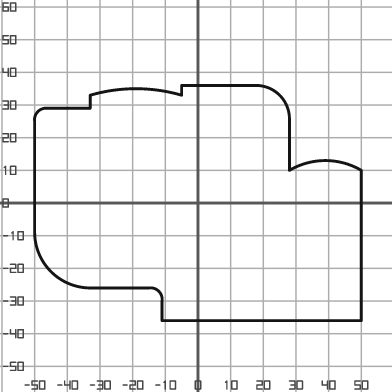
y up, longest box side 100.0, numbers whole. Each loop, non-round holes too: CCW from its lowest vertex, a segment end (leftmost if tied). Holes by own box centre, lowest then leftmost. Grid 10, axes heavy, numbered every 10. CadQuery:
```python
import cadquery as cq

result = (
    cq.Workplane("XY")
    .moveTo(-11.0, -36.0)
    .lineTo(50.0, -36.0)
    .lineTo(50.0, 10.0)
    .threePointArc((39.0, 13.0), (28.0, 10.0))
    .lineTo(28.0, 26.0)
    .threePointArc((25.0, 33.0), (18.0, 36.0))
    .lineTo(-5.0, 36.0)
    .lineTo(-5.0, 33.0)
    .threePointArc((-19.0, 35.0), (-33.0, 33.0))
    .lineTo(-33.0, 29.0)
    .lineTo(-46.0, 29.0)
    .threePointArc((-49.0, 28.0), (-50.0, 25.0))
    .lineTo(-50.0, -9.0)
    .threePointArc((-45.0, -21.0), (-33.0, -26.0))
    .lineTo(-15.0, -26.0)
    .threePointArc((-12.0, -27.0), (-11.0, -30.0))
    .close()
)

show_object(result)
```